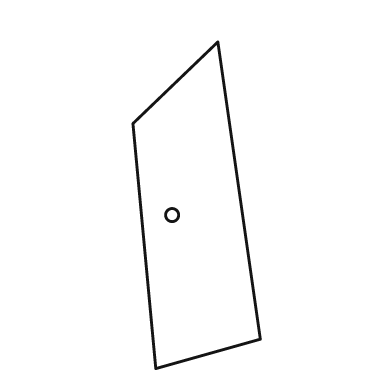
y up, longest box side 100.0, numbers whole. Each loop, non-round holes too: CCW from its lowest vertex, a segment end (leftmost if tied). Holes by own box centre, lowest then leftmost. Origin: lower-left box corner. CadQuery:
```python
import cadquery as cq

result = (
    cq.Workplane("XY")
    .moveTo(7.0, 0.0)
    .lineTo(39.0, 9.0)
    .lineTo(26.0, 100.0)
    .lineTo(0.0, 75.0)
    .close()
    .moveTo(12.0, 47.0)
    .circle(2.0)
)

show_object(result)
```